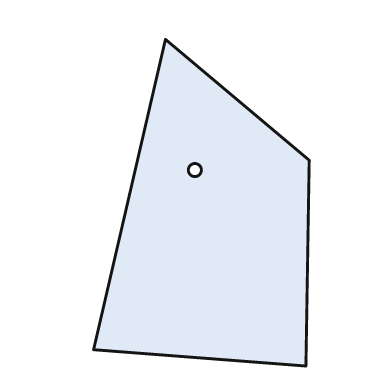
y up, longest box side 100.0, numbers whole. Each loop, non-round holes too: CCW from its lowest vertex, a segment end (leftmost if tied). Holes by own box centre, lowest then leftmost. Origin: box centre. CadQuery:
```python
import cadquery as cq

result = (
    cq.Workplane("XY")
    .moveTo(32.0, -50.0)
    .lineTo(33.0, 13.0)
    .lineTo(-11.0, 50.0)
    .lineTo(-33.0, -45.0)
    .close()
    .moveTo(-2.0, 10.0)
    .circle(2.0)
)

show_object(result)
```